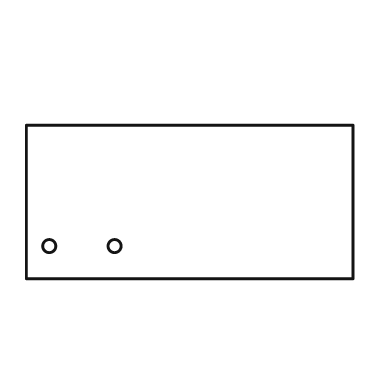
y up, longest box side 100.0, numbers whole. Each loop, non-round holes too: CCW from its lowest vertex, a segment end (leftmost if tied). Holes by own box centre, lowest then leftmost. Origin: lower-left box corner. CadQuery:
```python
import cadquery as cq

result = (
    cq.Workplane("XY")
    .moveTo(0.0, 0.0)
    .lineTo(100.0, 0.0)
    .lineTo(100.0, 47.0)
    .lineTo(0.0, 47.0)
    .close()
    .moveTo(7.0, 10.0)
    .circle(2.0)
    .moveTo(27.0, 10.0)
    .circle(2.0)
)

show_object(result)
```